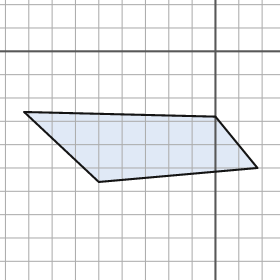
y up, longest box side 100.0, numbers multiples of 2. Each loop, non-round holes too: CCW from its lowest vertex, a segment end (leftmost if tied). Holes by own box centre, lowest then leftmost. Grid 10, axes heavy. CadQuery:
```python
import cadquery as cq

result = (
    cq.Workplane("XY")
    .moveTo(-50.0, -56.0)
    .lineTo(18.0, -50.0)
    .lineTo(0.0, -28.0)
    .lineTo(-82.0, -26.0)
    .close()
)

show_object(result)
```